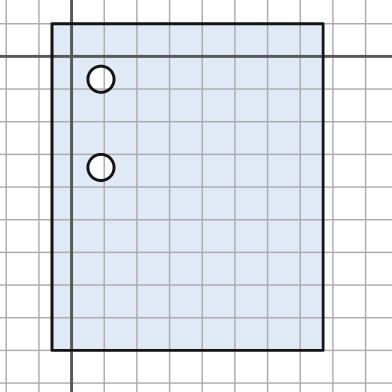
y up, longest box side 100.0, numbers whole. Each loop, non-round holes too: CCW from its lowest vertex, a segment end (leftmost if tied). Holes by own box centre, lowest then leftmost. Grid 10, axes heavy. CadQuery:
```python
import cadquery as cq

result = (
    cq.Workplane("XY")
    .moveTo(-6.0, -90.0)
    .lineTo(77.0, -90.0)
    .lineTo(77.0, 10.0)
    .lineTo(-6.0, 10.0)
    .close()
    .moveTo(9.0, -34.0)
    .circle(4.0)
    .moveTo(9.0, -7.0)
    .circle(4.0)
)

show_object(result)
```